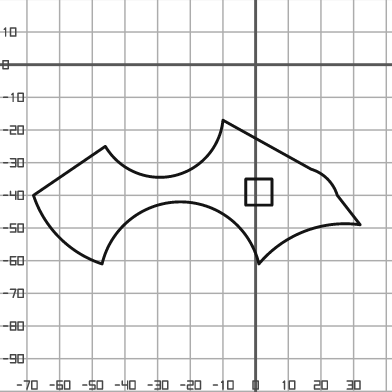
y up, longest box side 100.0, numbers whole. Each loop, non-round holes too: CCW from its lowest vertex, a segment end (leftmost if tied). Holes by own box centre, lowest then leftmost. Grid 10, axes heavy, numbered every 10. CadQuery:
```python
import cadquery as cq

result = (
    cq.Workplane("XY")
    .moveTo(-47.0, -61.0)
    .threePointArc((-23.0, -42.0), (1.0, -61.0))
    .threePointArc((15.0, -51.0), (32.0, -49.0))
    .lineTo(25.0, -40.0)
    .threePointArc((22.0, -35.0), (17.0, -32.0))
    .lineTo(-10.0, -17.0)
    .threePointArc((-25.0, -34.0), (-46.0, -25.0))
    .lineTo(-68.0, -40.0)
    .threePointArc((-60.0, -53.0), (-47.0, -61.0))
    .close()
    .moveTo(-3.0, -43.0)
    .lineTo(5.0, -43.0)
    .lineTo(5.0, -35.0)
    .lineTo(-3.0, -35.0)
    .close()
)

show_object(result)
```